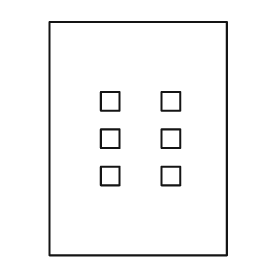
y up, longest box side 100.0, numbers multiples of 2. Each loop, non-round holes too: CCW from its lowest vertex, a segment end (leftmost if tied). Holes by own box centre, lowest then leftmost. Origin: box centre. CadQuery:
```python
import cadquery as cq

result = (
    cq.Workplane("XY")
    .moveTo(-38.0, -50.0)
    .lineTo(38.0, -50.0)
    .lineTo(38.0, 50.0)
    .lineTo(-38.0, 50.0)
    .close()
    .moveTo(-16.0, -20.0)
    .lineTo(-8.0, -20.0)
    .lineTo(-8.0, -12.0)
    .lineTo(-16.0, -12.0)
    .close()
    .moveTo(10.0, -20.0)
    .lineTo(18.0, -20.0)
    .lineTo(18.0, -12.0)
    .lineTo(10.0, -12.0)
    .close()
    .moveTo(-16.0, -4.0)
    .lineTo(-8.0, -4.0)
    .lineTo(-8.0, 4.0)
    .lineTo(-16.0, 4.0)
    .close()
    .moveTo(10.0, -4.0)
    .lineTo(18.0, -4.0)
    .lineTo(18.0, 4.0)
    .lineTo(10.0, 4.0)
    .close()
    .moveTo(-16.0, 12.0)
    .lineTo(-8.0, 12.0)
    .lineTo(-8.0, 20.0)
    .lineTo(-16.0, 20.0)
    .close()
    .moveTo(10.0, 12.0)
    .lineTo(18.0, 12.0)
    .lineTo(18.0, 20.0)
    .lineTo(10.0, 20.0)
    .close()
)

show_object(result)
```